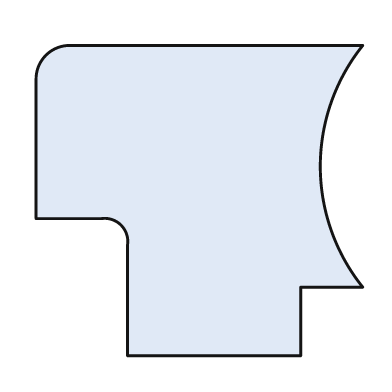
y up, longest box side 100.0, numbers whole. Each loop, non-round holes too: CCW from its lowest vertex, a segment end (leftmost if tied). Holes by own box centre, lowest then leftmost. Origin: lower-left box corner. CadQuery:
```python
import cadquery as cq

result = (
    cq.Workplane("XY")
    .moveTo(28.0, 0.0)
    .lineTo(81.0, 0.0)
    .lineTo(81.0, 21.0)
    .lineTo(100.0, 21.0)
    .threePointArc((87.0, 58.0), (100.0, 95.0))
    .lineTo(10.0, 95.0)
    .threePointArc((3.0, 92.0), (0.0, 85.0))
    .lineTo(0.0, 42.0)
    .lineTo(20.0, 42.0)
    .threePointArc((26.0, 40.0), (28.0, 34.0))
    .close()
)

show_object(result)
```